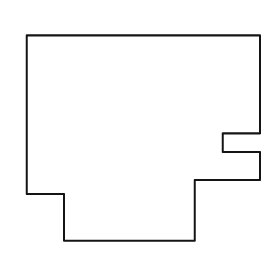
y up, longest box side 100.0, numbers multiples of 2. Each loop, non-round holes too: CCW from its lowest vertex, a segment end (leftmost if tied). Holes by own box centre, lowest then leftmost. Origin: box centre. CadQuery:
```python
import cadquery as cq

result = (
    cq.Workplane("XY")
    .moveTo(-34.0, -44.0)
    .lineTo(22.0, -44.0)
    .lineTo(22.0, -18.0)
    .lineTo(50.0, -18.0)
    .lineTo(50.0, -6.0)
    .lineTo(34.0, -6.0)
    .lineTo(34.0, 2.0)
    .lineTo(50.0, 2.0)
    .lineTo(50.0, 44.0)
    .lineTo(-50.0, 44.0)
    .lineTo(-50.0, -24.0)
    .lineTo(-34.0, -24.0)
    .close()
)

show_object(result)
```